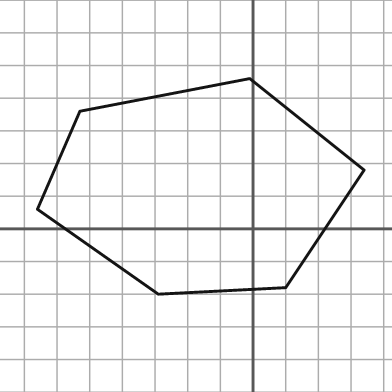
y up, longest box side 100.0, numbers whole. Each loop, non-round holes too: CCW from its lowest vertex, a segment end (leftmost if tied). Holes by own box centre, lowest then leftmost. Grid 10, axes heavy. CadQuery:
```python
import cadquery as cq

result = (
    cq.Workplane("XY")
    .moveTo(-29.0, -20.0)
    .lineTo(10.0, -18.0)
    .lineTo(34.0, 18.0)
    .lineTo(-1.0, 46.0)
    .lineTo(-53.0, 36.0)
    .lineTo(-66.0, 6.0)
    .close()
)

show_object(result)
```